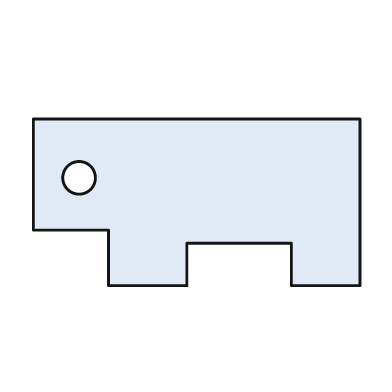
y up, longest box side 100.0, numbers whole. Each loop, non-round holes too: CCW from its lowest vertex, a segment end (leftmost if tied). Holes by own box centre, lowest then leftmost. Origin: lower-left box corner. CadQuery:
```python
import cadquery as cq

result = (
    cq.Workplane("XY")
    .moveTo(23.0, 0.0)
    .lineTo(47.0, 0.0)
    .lineTo(47.0, 13.0)
    .lineTo(79.0, 13.0)
    .lineTo(79.0, 0.0)
    .lineTo(100.0, 0.0)
    .lineTo(100.0, 51.0)
    .lineTo(0.0, 51.0)
    .lineTo(0.0, 17.0)
    .lineTo(23.0, 17.0)
    .close()
    .moveTo(14.0, 33.0)
    .circle(5.0)
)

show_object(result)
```